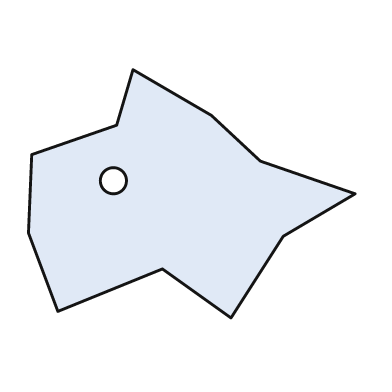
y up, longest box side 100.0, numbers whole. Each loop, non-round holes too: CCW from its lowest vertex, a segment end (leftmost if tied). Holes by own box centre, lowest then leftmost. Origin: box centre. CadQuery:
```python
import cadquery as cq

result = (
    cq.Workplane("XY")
    .moveTo(12.0, -38.0)
    .lineTo(28.0, -13.0)
    .lineTo(50.0, 0.0)
    .lineTo(21.0, 10.0)
    .lineTo(6.0, 24.0)
    .lineTo(-18.0, 38.0)
    .lineTo(-23.0, 21.0)
    .lineTo(-49.0, 12.0)
    .lineTo(-50.0, -12.0)
    .lineTo(-41.0, -36.0)
    .lineTo(-9.0, -23.0)
    .close()
    .moveTo(-24.0, 4.0)
    .circle(4.0)
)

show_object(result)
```